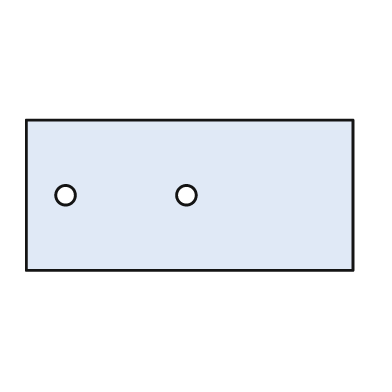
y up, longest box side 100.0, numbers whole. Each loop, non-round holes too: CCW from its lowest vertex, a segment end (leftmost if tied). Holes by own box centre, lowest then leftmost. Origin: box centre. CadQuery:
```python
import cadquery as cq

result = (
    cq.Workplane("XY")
    .moveTo(-50.0, -23.0)
    .lineTo(50.0, -23.0)
    .lineTo(50.0, 23.0)
    .lineTo(-50.0, 23.0)
    .close()
    .moveTo(-38.0, 0.0)
    .circle(3.0)
    .moveTo(-1.0, 0.0)
    .circle(3.0)
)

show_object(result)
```